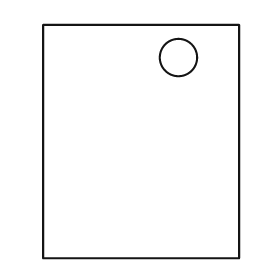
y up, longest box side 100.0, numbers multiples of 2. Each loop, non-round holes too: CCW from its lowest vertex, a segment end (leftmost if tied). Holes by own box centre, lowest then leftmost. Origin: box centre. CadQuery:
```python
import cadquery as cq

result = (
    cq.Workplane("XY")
    .moveTo(-42.0, -50.0)
    .lineTo(42.0, -50.0)
    .lineTo(42.0, 50.0)
    .lineTo(-42.0, 50.0)
    .close()
    .moveTo(16.0, 36.0)
    .circle(8.0)
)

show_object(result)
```